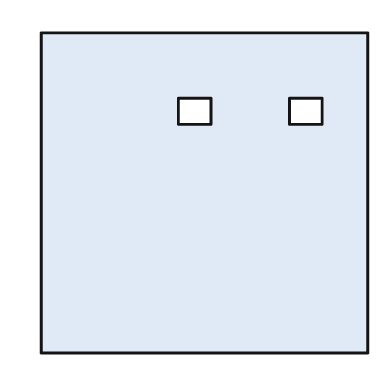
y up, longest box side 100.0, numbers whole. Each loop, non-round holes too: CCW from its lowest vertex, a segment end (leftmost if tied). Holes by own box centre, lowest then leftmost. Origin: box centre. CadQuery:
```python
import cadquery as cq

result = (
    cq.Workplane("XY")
    .moveTo(-50.0, -49.0)
    .lineTo(50.0, -49.0)
    .lineTo(50.0, 49.0)
    .lineTo(-50.0, 49.0)
    .close()
    .moveTo(-8.0, 21.0)
    .lineTo(2.0, 21.0)
    .lineTo(2.0, 29.0)
    .lineTo(-8.0, 29.0)
    .close()
    .moveTo(26.0, 21.0)
    .lineTo(36.0, 21.0)
    .lineTo(36.0, 29.0)
    .lineTo(26.0, 29.0)
    .close()
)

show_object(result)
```